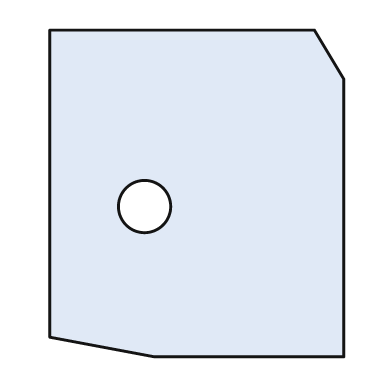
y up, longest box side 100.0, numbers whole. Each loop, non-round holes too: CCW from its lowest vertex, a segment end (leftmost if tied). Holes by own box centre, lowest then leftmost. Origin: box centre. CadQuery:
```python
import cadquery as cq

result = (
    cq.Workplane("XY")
    .moveTo(-13.0, -50.0)
    .lineTo(45.0, -50.0)
    .lineTo(45.0, 35.0)
    .lineTo(36.0, 50.0)
    .lineTo(-45.0, 50.0)
    .lineTo(-45.0, -44.0)
    .close()
    .moveTo(-16.0, -4.0)
    .circle(8.0)
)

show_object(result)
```